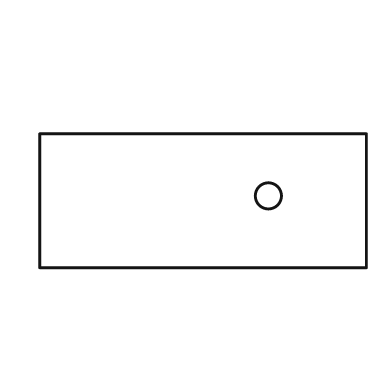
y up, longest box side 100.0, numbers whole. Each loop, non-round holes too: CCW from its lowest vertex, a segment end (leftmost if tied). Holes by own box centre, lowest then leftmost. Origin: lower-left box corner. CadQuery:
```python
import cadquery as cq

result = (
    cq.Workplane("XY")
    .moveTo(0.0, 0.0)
    .lineTo(100.0, 0.0)
    .lineTo(100.0, 41.0)
    .lineTo(0.0, 41.0)
    .close()
    .moveTo(70.0, 22.0)
    .circle(4.0)
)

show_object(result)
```